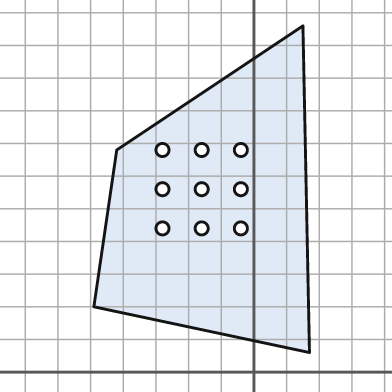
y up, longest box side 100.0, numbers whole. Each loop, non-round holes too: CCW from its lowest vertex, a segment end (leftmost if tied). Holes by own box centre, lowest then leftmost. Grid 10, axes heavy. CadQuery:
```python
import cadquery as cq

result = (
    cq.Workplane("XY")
    .moveTo(17.0, 6.0)
    .lineTo(15.0, 106.0)
    .lineTo(-42.0, 68.0)
    .lineTo(-49.0, 20.0)
    .close()
    .moveTo(-28.0, 44.0)
    .circle(2.0)
    .moveTo(-16.0, 44.0)
    .circle(2.0)
    .moveTo(-4.0, 44.0)
    .circle(2.0)
    .moveTo(-28.0, 56.0)
    .circle(2.0)
    .moveTo(-16.0, 56.0)
    .circle(2.0)
    .moveTo(-4.0, 56.0)
    .circle(2.0)
    .moveTo(-28.0, 68.0)
    .circle(2.0)
    .moveTo(-16.0, 68.0)
    .circle(2.0)
    .moveTo(-4.0, 68.0)
    .circle(2.0)
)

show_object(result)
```